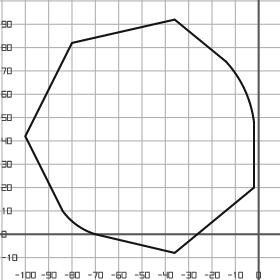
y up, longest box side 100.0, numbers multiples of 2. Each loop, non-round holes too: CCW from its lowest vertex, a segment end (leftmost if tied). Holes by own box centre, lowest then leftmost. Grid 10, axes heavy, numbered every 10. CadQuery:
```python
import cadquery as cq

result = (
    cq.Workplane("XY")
    .moveTo(-36.0, -8.0)
    .lineTo(-2.0, 20.0)
    .lineTo(-2.0, 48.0)
    .threePointArc((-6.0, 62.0), (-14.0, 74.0))
    .lineTo(-36.0, 92.0)
    .lineTo(-80.0, 82.0)
    .lineTo(-100.0, 42.0)
    .lineTo(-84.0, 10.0)
    .threePointArc((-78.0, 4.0), (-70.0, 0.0))
    .close()
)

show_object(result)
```